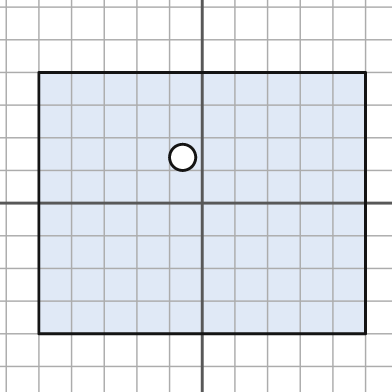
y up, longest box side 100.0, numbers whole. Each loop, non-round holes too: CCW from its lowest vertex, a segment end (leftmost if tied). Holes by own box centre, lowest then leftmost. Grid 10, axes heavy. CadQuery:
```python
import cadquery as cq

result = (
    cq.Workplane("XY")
    .moveTo(-50.0, -40.0)
    .lineTo(50.0, -40.0)
    .lineTo(50.0, 40.0)
    .lineTo(-50.0, 40.0)
    .close()
    .moveTo(-6.0, 14.0)
    .circle(4.0)
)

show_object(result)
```